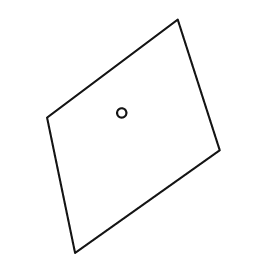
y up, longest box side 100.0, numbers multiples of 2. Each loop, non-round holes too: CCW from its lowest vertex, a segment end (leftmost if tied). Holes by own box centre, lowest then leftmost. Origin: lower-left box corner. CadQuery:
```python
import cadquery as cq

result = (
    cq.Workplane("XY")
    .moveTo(12.0, 0.0)
    .lineTo(74.0, 44.0)
    .lineTo(56.0, 100.0)
    .lineTo(0.0, 58.0)
    .close()
    .moveTo(32.0, 60.0)
    .circle(2.0)
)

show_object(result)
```